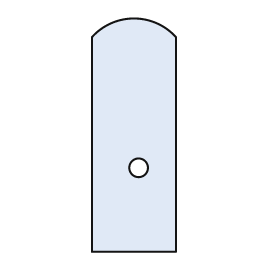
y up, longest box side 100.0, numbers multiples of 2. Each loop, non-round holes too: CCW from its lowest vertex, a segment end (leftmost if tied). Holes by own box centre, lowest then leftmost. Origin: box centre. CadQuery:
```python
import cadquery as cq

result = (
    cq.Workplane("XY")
    .moveTo(-18.0, -50.0)
    .lineTo(18.0, -50.0)
    .lineTo(18.0, 42.0)
    .threePointArc((0.0, 50.0), (-18.0, 42.0))
    .close()
    .moveTo(2.0, -14.0)
    .circle(4.0)
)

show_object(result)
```